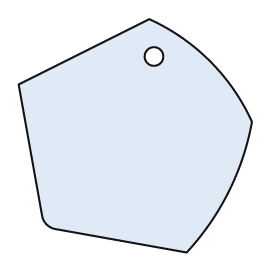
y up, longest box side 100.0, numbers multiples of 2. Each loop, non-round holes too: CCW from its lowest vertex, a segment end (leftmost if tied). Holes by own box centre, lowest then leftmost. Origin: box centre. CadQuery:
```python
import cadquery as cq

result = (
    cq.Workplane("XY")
    .moveTo(22.0, -50.0)
    .threePointArc((40.0, -24.0), (50.0, 6.0))
    .threePointArc((32.0, 32.0), (6.0, 50.0))
    .lineTo(-50.0, 22.0)
    .lineTo(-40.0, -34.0)
    .threePointArc((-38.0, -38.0), (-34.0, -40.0))
    .close()
    .moveTo(8.0, 34.0)
    .circle(4.0)
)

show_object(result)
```